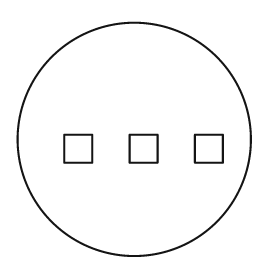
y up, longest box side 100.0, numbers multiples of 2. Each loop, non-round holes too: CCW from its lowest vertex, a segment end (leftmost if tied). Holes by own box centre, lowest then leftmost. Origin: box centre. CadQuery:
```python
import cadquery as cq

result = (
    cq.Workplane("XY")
    .moveTo(0.0, 0.0)
    .circle(50.0)
    .moveTo(-30.0, -10.0)
    .lineTo(-18.0, -10.0)
    .lineTo(-18.0, 2.0)
    .lineTo(-30.0, 2.0)
    .close()
    .moveTo(-2.0, -10.0)
    .lineTo(10.0, -10.0)
    .lineTo(10.0, 2.0)
    .lineTo(-2.0, 2.0)
    .close()
    .moveTo(26.0, -10.0)
    .lineTo(38.0, -10.0)
    .lineTo(38.0, 2.0)
    .lineTo(26.0, 2.0)
    .close()
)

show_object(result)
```